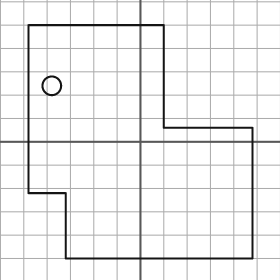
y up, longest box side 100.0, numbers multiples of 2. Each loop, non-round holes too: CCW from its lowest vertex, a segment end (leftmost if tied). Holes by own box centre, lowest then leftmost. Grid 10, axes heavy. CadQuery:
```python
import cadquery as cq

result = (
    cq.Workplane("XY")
    .moveTo(-32.0, -50.0)
    .lineTo(48.0, -50.0)
    .lineTo(48.0, 6.0)
    .lineTo(10.0, 6.0)
    .lineTo(10.0, 50.0)
    .lineTo(-48.0, 50.0)
    .lineTo(-48.0, -22.0)
    .lineTo(-32.0, -22.0)
    .close()
    .moveTo(-38.0, 24.0)
    .circle(4.0)
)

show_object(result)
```